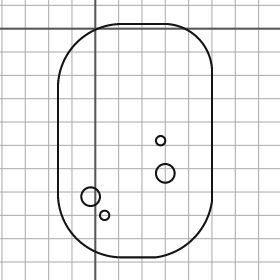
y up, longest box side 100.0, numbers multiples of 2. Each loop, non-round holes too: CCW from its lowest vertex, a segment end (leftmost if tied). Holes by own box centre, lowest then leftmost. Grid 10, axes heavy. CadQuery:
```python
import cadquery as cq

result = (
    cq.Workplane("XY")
    .moveTo(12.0, -98.0)
    .lineTo(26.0, -98.0)
    .threePointArc((42.0, -90.0), (50.0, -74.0))
    .lineTo(50.0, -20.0)
    .threePointArc((44.0, -4.0), (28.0, 2.0))
    .lineTo(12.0, 2.0)
    .threePointArc((-8.0, -6.0), (-16.0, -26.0))
    .lineTo(-16.0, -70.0)
    .threePointArc((-8.0, -90.0), (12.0, -98.0))
    .close()
    .moveTo(4.0, -80.0)
    .circle(2.0)
    .moveTo(-2.0, -72.0)
    .circle(4.0)
    .moveTo(30.0, -62.0)
    .circle(4.0)
    .moveTo(28.0, -48.0)
    .circle(2.0)
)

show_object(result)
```